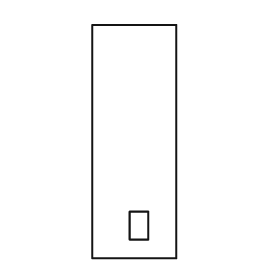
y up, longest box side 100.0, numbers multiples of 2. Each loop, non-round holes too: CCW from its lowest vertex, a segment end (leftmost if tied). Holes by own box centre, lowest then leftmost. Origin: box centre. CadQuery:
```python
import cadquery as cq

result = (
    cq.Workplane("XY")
    .moveTo(-18.0, -50.0)
    .lineTo(18.0, -50.0)
    .lineTo(18.0, 50.0)
    .lineTo(-18.0, 50.0)
    .close()
    .moveTo(-2.0, -42.0)
    .lineTo(6.0, -42.0)
    .lineTo(6.0, -30.0)
    .lineTo(-2.0, -30.0)
    .close()
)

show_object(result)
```